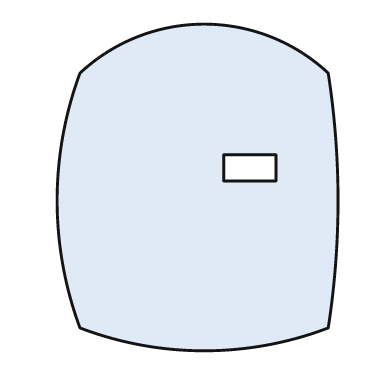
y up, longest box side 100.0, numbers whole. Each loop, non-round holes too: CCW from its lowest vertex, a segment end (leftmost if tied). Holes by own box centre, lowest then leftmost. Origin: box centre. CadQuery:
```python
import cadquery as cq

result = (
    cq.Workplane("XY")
    .moveTo(-36.0, -43.0)
    .threePointArc((2.0, -50.0), (40.0, -43.0))
    .threePointArc((43.0, -4.0), (40.0, 35.0))
    .threePointArc((2.0, 50.0), (-36.0, 35.0))
    .threePointArc((-43.0, -4.0), (-36.0, -43.0))
    .close()
    .moveTo(8.0, 2.0)
    .lineTo(24.0, 2.0)
    .lineTo(24.0, 10.0)
    .lineTo(8.0, 10.0)
    .close()
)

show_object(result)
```